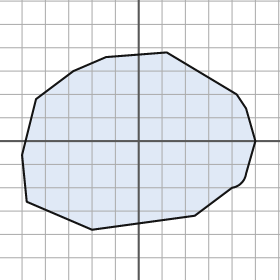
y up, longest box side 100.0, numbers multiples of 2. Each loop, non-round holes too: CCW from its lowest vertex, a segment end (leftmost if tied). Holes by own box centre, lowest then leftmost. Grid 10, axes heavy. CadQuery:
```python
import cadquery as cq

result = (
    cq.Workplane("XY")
    .moveTo(-20.0, -38.0)
    .lineTo(24.0, -32.0)
    .lineTo(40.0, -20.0)
    .threePointArc((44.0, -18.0), (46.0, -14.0))
    .lineTo(50.0, 0.0)
    .lineTo(46.0, 14.0)
    .lineTo(42.0, 20.0)
    .lineTo(12.0, 38.0)
    .lineTo(-14.0, 36.0)
    .lineTo(-28.0, 30.0)
    .lineTo(-44.0, 18.0)
    .lineTo(-50.0, -6.0)
    .lineTo(-48.0, -26.0)
    .close()
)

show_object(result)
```